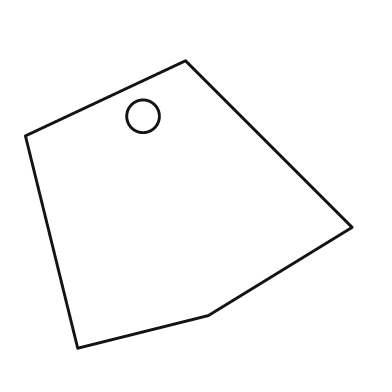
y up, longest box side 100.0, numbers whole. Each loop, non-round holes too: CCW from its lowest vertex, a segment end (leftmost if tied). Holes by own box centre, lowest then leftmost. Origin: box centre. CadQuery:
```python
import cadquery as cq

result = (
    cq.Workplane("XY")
    .moveTo(-34.0, -44.0)
    .lineTo(6.0, -34.0)
    .lineTo(50.0, -7.0)
    .lineTo(-1.0, 44.0)
    .lineTo(-50.0, 21.0)
    .close()
    .moveTo(-14.0, 27.0)
    .circle(5.0)
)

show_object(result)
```